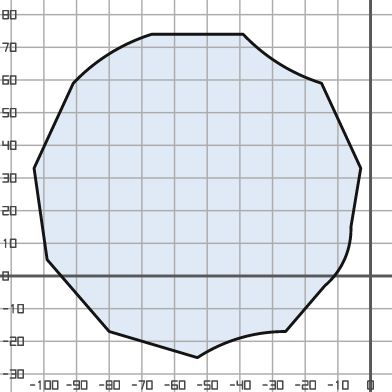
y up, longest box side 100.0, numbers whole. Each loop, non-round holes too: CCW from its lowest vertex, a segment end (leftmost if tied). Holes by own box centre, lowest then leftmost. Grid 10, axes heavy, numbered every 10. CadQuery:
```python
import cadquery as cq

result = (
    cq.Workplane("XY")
    .moveTo(-53.0, -25.0)
    .threePointArc((-40.0, -19.0), (-26.0, -17.0))
    .lineTo(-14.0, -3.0)
    .threePointArc((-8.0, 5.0), (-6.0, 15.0))
    .lineTo(-3.0, 33.0)
    .lineTo(-15.0, 59.0)
    .threePointArc((-28.0, 65.0), (-39.0, 74.0))
    .lineTo(-67.0, 74.0)
    .threePointArc((-80.0, 68.0), (-91.0, 59.0))
    .lineTo(-103.0, 33.0)
    .lineTo(-99.0, 5.0)
    .lineTo(-80.0, -17.0)
    .close()
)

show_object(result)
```